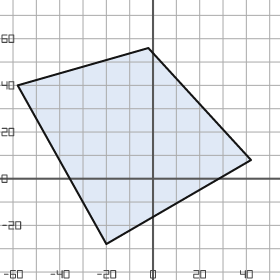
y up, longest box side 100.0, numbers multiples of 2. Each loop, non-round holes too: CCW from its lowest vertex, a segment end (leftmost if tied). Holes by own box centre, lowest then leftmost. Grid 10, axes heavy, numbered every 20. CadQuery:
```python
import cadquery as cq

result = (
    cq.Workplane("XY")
    .moveTo(-20.0, -28.0)
    .lineTo(42.0, 8.0)
    .lineTo(-2.0, 56.0)
    .lineTo(-58.0, 40.0)
    .close()
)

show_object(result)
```